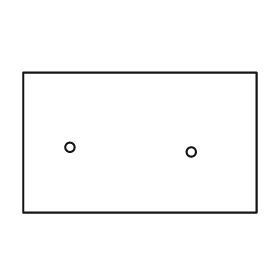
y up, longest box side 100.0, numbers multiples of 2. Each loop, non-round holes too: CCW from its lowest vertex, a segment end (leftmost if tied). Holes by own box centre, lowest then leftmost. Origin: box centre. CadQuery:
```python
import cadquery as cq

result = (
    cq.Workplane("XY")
    .moveTo(-50.0, -30.0)
    .lineTo(50.0, -30.0)
    .lineTo(50.0, 30.0)
    .lineTo(-50.0, 30.0)
    .close()
    .moveTo(22.0, -4.0)
    .circle(2.0)
    .moveTo(-30.0, -2.0)
    .circle(2.0)
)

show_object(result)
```